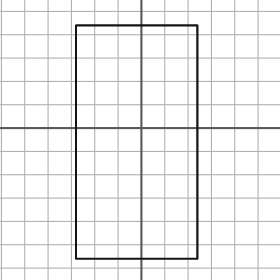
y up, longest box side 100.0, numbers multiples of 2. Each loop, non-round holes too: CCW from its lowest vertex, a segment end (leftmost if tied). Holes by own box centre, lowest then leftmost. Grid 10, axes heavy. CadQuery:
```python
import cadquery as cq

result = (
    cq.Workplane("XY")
    .moveTo(-28.0, -56.0)
    .lineTo(24.0, -56.0)
    .lineTo(24.0, 44.0)
    .lineTo(-28.0, 44.0)
    .close()
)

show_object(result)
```